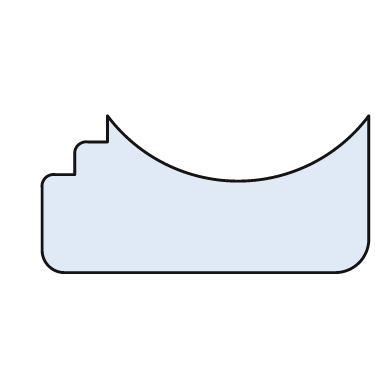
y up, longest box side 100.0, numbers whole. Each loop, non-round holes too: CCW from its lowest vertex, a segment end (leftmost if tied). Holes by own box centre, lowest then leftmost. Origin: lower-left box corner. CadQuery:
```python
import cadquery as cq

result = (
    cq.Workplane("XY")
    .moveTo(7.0, 0.0)
    .lineTo(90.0, 0.0)
    .threePointArc((97.0, 3.0), (100.0, 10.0))
    .lineTo(100.0, 48.0)
    .threePointArc((60.0, 28.0), (20.0, 48.0))
    .lineTo(20.0, 40.0)
    .lineTo(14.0, 40.0)
    .threePointArc((11.0, 39.0), (10.0, 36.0))
    .lineTo(10.0, 30.0)
    .lineTo(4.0, 30.0)
    .threePointArc((1.0, 29.0), (0.0, 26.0))
    .lineTo(0.0, 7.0)
    .threePointArc((2.0, 2.0), (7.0, 0.0))
    .close()
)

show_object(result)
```